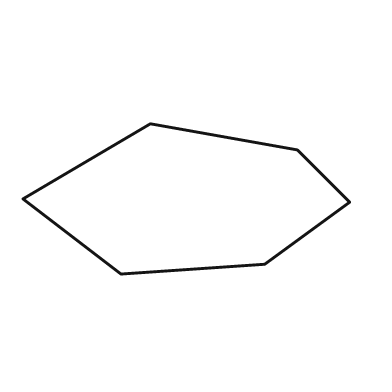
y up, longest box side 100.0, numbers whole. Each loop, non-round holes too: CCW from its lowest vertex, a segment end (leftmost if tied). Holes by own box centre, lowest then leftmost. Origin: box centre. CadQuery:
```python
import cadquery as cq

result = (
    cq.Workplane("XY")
    .moveTo(-20.0, -23.0)
    .lineTo(24.0, -20.0)
    .lineTo(50.0, -1.0)
    .lineTo(34.0, 15.0)
    .lineTo(-11.0, 23.0)
    .lineTo(-50.0, 0.0)
    .close()
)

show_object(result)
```